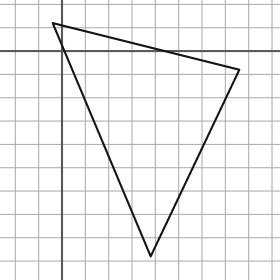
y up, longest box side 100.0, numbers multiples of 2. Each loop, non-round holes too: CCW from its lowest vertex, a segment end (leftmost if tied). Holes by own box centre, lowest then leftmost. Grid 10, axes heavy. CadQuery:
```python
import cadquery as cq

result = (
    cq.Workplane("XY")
    .moveTo(38.0, -88.0)
    .lineTo(76.0, -8.0)
    .lineTo(-4.0, 12.0)
    .close()
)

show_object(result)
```